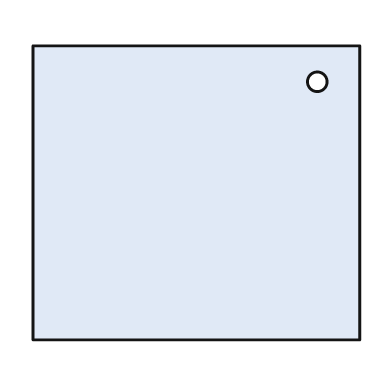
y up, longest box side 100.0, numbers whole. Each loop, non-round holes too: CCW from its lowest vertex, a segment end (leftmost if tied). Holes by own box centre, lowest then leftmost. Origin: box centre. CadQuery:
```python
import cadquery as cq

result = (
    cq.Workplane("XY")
    .moveTo(-50.0, -45.0)
    .lineTo(50.0, -45.0)
    .lineTo(50.0, 45.0)
    .lineTo(-50.0, 45.0)
    .close()
    .moveTo(37.0, 34.0)
    .circle(3.0)
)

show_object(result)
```